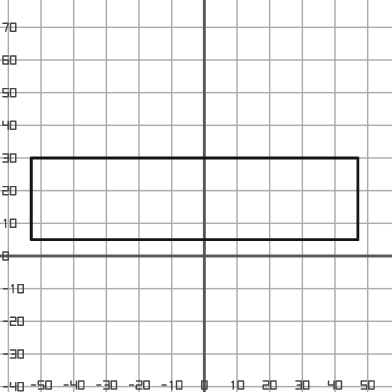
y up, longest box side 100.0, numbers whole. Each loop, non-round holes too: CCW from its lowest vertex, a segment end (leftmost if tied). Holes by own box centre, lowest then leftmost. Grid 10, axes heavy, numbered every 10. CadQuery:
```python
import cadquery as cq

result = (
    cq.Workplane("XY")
    .moveTo(-53.0, 5.0)
    .lineTo(47.0, 5.0)
    .lineTo(47.0, 30.0)
    .lineTo(-53.0, 30.0)
    .close()
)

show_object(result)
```